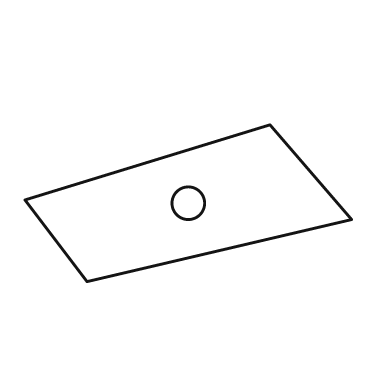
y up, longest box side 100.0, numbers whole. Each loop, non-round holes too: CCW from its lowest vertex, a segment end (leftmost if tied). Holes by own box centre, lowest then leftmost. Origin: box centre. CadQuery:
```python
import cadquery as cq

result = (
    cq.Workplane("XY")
    .moveTo(-31.0, -24.0)
    .lineTo(50.0, -5.0)
    .lineTo(25.0, 24.0)
    .lineTo(-50.0, 1.0)
    .close()
    .moveTo(0.0, 0.0)
    .circle(5.0)
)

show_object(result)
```